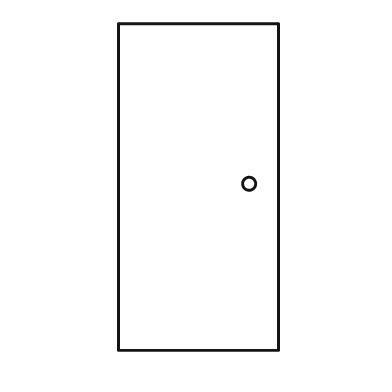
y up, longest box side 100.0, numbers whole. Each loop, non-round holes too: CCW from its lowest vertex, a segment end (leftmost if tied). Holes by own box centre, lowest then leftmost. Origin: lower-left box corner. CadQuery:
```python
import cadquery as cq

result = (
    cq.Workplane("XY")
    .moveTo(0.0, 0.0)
    .lineTo(49.0, 0.0)
    .lineTo(49.0, 100.0)
    .lineTo(0.0, 100.0)
    .close()
    .moveTo(40.0, 51.0)
    .circle(2.0)
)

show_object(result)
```